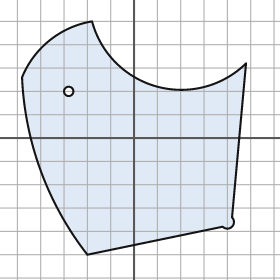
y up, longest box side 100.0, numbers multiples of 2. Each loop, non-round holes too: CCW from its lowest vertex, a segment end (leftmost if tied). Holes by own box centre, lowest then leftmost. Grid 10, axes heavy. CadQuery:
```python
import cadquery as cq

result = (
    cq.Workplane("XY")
    .moveTo(-20.0, -50.0)
    .lineTo(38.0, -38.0)
    .threePointArc((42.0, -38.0), (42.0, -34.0))
    .lineTo(48.0, 32.0)
    .threePointArc((10.0, 22.0), (-18.0, 50.0))
    .threePointArc((-36.0, 42.0), (-48.0, 26.0))
    .threePointArc((-40.0, -14.0), (-20.0, -50.0))
    .close()
    .moveTo(-28.0, 20.0)
    .circle(2.0)
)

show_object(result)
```